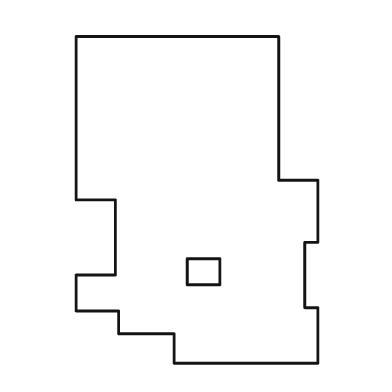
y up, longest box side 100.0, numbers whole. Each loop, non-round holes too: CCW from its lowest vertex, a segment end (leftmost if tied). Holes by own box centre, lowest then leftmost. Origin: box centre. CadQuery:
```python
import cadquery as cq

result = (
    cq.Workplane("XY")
    .moveTo(-7.0, -50.0)
    .lineTo(37.0, -50.0)
    .lineTo(37.0, -33.0)
    .lineTo(33.0, -33.0)
    .lineTo(33.0, -13.0)
    .lineTo(37.0, -13.0)
    .lineTo(37.0, 6.0)
    .lineTo(25.0, 6.0)
    .lineTo(25.0, 50.0)
    .lineTo(-37.0, 50.0)
    .lineTo(-37.0, 0.0)
    .lineTo(-25.0, 0.0)
    .lineTo(-25.0, -23.0)
    .lineTo(-37.0, -23.0)
    .lineTo(-37.0, -34.0)
    .lineTo(-24.0, -34.0)
    .lineTo(-24.0, -41.0)
    .lineTo(-7.0, -41.0)
    .close()
    .moveTo(-3.0, -26.0)
    .lineTo(7.0, -26.0)
    .lineTo(7.0, -18.0)
    .lineTo(-3.0, -18.0)
    .close()
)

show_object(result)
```